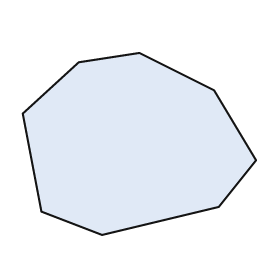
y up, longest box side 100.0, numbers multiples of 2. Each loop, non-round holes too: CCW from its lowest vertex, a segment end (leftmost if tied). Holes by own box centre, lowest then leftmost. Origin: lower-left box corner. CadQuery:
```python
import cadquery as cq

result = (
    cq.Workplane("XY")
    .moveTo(34.0, 0.0)
    .lineTo(84.0, 12.0)
    .lineTo(100.0, 32.0)
    .lineTo(82.0, 62.0)
    .lineTo(50.0, 78.0)
    .lineTo(24.0, 74.0)
    .lineTo(0.0, 52.0)
    .lineTo(8.0, 10.0)
    .close()
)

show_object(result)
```